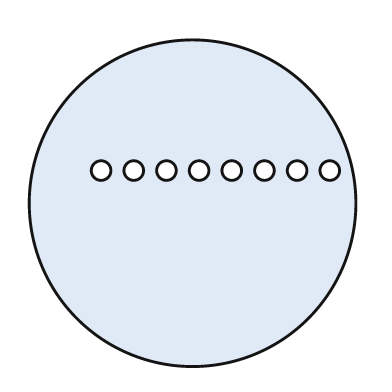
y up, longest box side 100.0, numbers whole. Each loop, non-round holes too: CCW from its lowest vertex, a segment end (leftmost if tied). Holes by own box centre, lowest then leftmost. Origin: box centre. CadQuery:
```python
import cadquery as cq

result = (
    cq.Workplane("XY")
    .moveTo(0.0, 0.0)
    .circle(50.0)
    .moveTo(-28.0, 10.0)
    .circle(3.0)
    .moveTo(-18.0, 10.0)
    .circle(3.0)
    .moveTo(-8.0, 10.0)
    .circle(3.0)
    .moveTo(2.0, 10.0)
    .circle(3.0)
    .moveTo(12.0, 10.0)
    .circle(3.0)
    .moveTo(22.0, 10.0)
    .circle(3.0)
    .moveTo(32.0, 10.0)
    .circle(3.0)
    .moveTo(42.0, 10.0)
    .circle(3.0)
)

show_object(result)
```